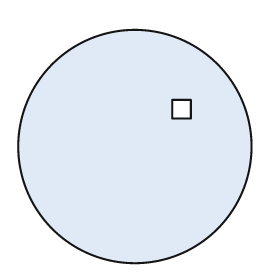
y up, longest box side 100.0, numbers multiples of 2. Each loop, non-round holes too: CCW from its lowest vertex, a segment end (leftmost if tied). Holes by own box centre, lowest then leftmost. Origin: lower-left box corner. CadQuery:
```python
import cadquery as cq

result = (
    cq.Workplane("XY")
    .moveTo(50.0, 50.0)
    .circle(50.0)
    .moveTo(66.0, 62.0)
    .lineTo(74.0, 62.0)
    .lineTo(74.0, 70.0)
    .lineTo(66.0, 70.0)
    .close()
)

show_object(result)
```